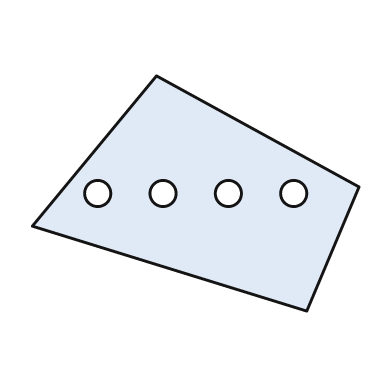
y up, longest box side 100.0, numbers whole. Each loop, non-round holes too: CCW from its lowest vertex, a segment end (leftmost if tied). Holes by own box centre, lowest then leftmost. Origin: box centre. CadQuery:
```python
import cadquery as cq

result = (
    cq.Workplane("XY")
    .moveTo(34.0, -36.0)
    .lineTo(50.0, 2.0)
    .lineTo(-12.0, 36.0)
    .lineTo(-50.0, -10.0)
    .close()
    .moveTo(-30.0, 0.0)
    .circle(4.0)
    .moveTo(-10.0, 0.0)
    .circle(4.0)
    .moveTo(10.0, 0.0)
    .circle(4.0)
    .moveTo(30.0, 0.0)
    .circle(4.0)
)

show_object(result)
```